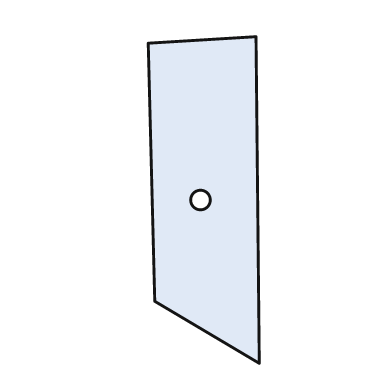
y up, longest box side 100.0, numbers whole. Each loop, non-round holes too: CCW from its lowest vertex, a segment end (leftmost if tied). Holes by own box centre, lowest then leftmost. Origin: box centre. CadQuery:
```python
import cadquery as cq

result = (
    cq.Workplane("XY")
    .moveTo(17.0, -50.0)
    .lineTo(16.0, 50.0)
    .lineTo(-17.0, 48.0)
    .lineTo(-15.0, -31.0)
    .close()
    .moveTo(-1.0, 0.0)
    .circle(3.0)
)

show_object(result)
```